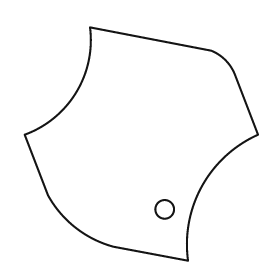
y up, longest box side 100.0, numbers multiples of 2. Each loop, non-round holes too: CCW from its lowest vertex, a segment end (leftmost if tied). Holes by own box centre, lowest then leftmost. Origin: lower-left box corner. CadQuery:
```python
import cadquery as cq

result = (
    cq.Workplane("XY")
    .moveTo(70.0, 0.0)
    .threePointArc((76.0, 32.0), (100.0, 54.0))
    .lineTo(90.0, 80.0)
    .threePointArc((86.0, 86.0), (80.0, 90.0))
    .lineTo(28.0, 100.0)
    .threePointArc((22.0, 72.0), (0.0, 54.0))
    .lineTo(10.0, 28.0)
    .threePointArc((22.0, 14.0), (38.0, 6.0))
    .close()
    .moveTo(60.0, 22.0)
    .circle(4.0)
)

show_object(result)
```